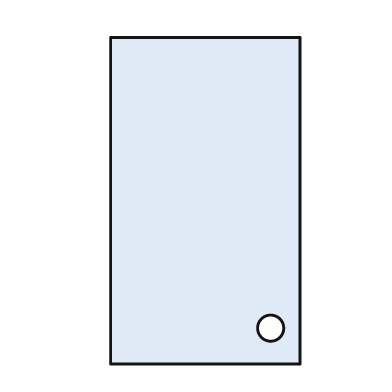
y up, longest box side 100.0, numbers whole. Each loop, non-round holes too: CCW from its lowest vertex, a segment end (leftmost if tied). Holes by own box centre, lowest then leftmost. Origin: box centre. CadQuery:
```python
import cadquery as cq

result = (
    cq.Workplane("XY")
    .moveTo(-29.0, -50.0)
    .lineTo(29.0, -50.0)
    .lineTo(29.0, 50.0)
    .lineTo(-29.0, 50.0)
    .close()
    .moveTo(20.0, -39.0)
    .circle(4.0)
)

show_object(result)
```